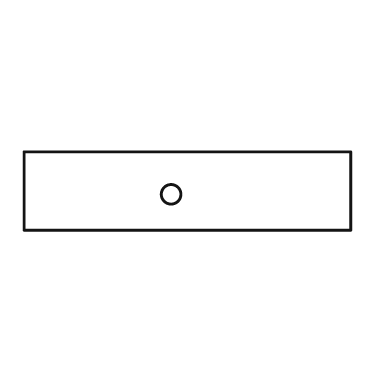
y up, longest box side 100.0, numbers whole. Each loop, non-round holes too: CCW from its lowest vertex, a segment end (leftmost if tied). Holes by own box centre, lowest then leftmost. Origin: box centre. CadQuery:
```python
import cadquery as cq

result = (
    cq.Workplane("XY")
    .moveTo(-50.0, -12.0)
    .lineTo(50.0, -12.0)
    .lineTo(50.0, 12.0)
    .lineTo(-50.0, 12.0)
    .close()
    .moveTo(-5.0, -1.0)
    .circle(3.0)
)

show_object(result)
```